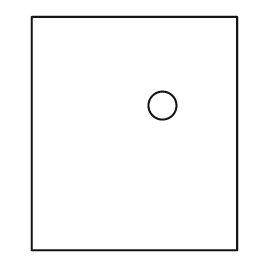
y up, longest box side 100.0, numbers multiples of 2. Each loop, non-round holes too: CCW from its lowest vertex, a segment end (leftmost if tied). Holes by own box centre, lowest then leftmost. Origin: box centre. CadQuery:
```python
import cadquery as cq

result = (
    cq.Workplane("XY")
    .moveTo(-44.0, -50.0)
    .lineTo(44.0, -50.0)
    .lineTo(44.0, 50.0)
    .lineTo(-44.0, 50.0)
    .close()
    .moveTo(12.0, 12.0)
    .circle(6.0)
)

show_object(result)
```